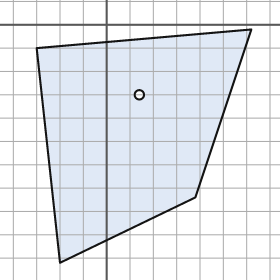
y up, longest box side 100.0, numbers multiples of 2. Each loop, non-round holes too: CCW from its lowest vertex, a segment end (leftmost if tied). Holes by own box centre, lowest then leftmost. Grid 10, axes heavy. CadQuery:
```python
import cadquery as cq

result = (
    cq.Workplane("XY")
    .moveTo(-20.0, -102.0)
    .lineTo(38.0, -74.0)
    .lineTo(62.0, -2.0)
    .lineTo(-30.0, -10.0)
    .close()
    .moveTo(14.0, -30.0)
    .circle(2.0)
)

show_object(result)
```